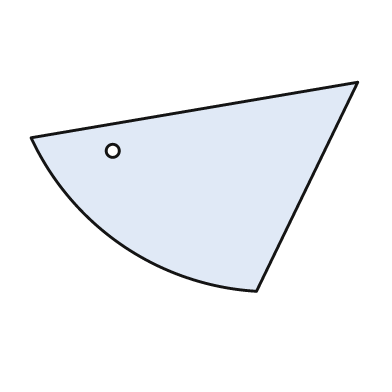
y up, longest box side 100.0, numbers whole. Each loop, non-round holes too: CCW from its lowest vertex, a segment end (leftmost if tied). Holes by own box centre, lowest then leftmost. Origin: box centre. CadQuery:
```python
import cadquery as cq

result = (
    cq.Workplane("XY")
    .moveTo(19.0, -32.0)
    .lineTo(50.0, 32.0)
    .lineTo(-50.0, 15.0)
    .threePointArc((-22.0, -18.0), (19.0, -32.0))
    .close()
    .moveTo(-25.0, 11.0)
    .circle(2.0)
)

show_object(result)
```